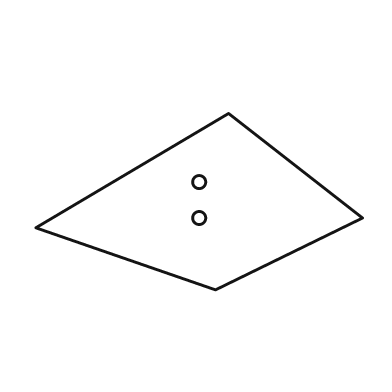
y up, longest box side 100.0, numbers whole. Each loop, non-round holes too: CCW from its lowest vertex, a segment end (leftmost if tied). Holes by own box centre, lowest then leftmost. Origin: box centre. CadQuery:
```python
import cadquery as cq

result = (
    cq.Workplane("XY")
    .moveTo(5.0, -27.0)
    .lineTo(50.0, -5.0)
    .lineTo(9.0, 27.0)
    .lineTo(-50.0, -8.0)
    .close()
    .moveTo(0.0, -5.0)
    .circle(2.0)
    .moveTo(0.0, 6.0)
    .circle(2.0)
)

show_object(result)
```